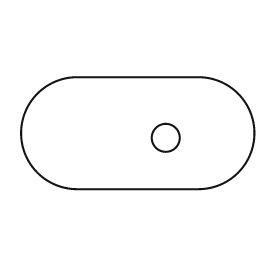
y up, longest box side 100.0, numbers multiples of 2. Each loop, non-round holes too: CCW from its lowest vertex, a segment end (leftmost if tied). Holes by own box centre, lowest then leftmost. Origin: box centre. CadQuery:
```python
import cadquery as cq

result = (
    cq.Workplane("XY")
    .moveTo(-26.0, -24.0)
    .lineTo(26.0, -24.0)
    .threePointArc((50.0, 0.0), (26.0, 24.0))
    .lineTo(-26.0, 24.0)
    .threePointArc((-50.0, 0.0), (-26.0, -24.0))
    .close()
    .moveTo(12.0, -2.0)
    .circle(6.0)
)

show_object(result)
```